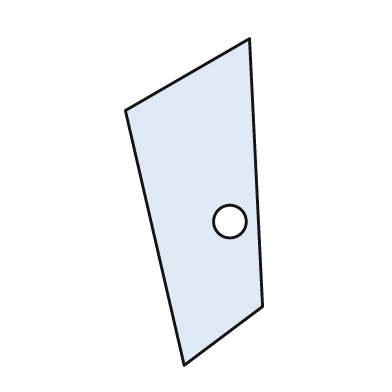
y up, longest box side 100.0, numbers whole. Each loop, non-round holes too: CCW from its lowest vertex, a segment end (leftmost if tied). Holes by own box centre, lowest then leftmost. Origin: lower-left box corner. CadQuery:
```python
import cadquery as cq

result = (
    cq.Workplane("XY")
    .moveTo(18.0, 0.0)
    .lineTo(42.0, 18.0)
    .lineTo(38.0, 100.0)
    .lineTo(0.0, 78.0)
    .close()
    .moveTo(32.0, 44.0)
    .circle(5.0)
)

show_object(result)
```